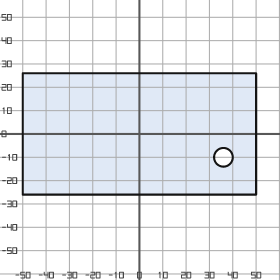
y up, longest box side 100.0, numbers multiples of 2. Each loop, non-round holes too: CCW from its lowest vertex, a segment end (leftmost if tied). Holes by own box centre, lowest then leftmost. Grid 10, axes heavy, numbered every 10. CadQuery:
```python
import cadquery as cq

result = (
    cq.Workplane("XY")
    .moveTo(-50.0, -26.0)
    .lineTo(50.0, -26.0)
    .lineTo(50.0, 26.0)
    .lineTo(-50.0, 26.0)
    .close()
    .moveTo(36.0, -10.0)
    .circle(4.0)
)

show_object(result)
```